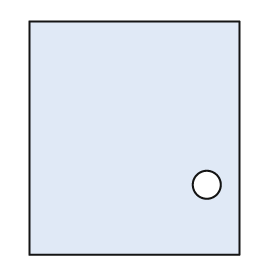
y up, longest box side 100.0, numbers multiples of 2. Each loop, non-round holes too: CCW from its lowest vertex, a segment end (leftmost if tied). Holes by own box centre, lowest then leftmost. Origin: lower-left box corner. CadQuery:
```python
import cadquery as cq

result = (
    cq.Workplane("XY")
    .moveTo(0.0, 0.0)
    .lineTo(90.0, 0.0)
    .lineTo(90.0, 100.0)
    .lineTo(0.0, 100.0)
    .close()
    .moveTo(76.0, 30.0)
    .circle(6.0)
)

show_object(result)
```